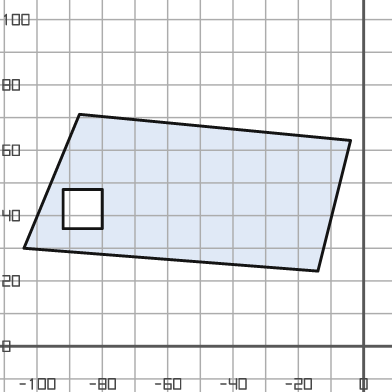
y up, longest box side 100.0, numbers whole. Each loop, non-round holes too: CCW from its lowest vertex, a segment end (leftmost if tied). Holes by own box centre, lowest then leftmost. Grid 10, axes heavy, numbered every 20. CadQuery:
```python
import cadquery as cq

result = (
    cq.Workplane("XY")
    .moveTo(-14.0, 23.0)
    .lineTo(-4.0, 63.0)
    .lineTo(-87.0, 71.0)
    .lineTo(-104.0, 30.0)
    .close()
    .moveTo(-92.0, 36.0)
    .lineTo(-80.0, 36.0)
    .lineTo(-80.0, 48.0)
    .lineTo(-92.0, 48.0)
    .close()
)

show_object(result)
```